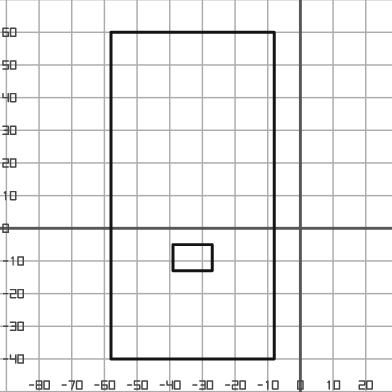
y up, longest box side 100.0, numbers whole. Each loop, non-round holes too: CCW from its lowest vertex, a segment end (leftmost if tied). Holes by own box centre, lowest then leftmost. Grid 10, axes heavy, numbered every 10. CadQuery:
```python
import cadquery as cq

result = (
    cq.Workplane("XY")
    .moveTo(-58.0, -40.0)
    .lineTo(-8.0, -40.0)
    .lineTo(-8.0, 60.0)
    .lineTo(-58.0, 60.0)
    .close()
    .moveTo(-39.0, -13.0)
    .lineTo(-27.0, -13.0)
    .lineTo(-27.0, -5.0)
    .lineTo(-39.0, -5.0)
    .close()
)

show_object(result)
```